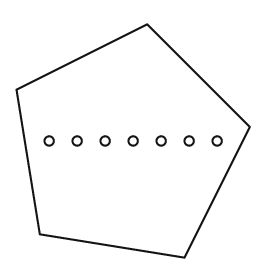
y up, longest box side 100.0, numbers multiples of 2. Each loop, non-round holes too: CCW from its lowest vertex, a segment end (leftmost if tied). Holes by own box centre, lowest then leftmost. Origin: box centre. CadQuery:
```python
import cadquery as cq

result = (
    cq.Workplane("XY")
    .moveTo(22.0, -50.0)
    .lineTo(50.0, 6.0)
    .lineTo(6.0, 50.0)
    .lineTo(-50.0, 22.0)
    .lineTo(-40.0, -40.0)
    .close()
    .moveTo(-36.0, 0.0)
    .circle(2.0)
    .moveTo(-24.0, 0.0)
    .circle(2.0)
    .moveTo(-12.0, 0.0)
    .circle(2.0)
    .moveTo(0.0, 0.0)
    .circle(2.0)
    .moveTo(12.0, 0.0)
    .circle(2.0)
    .moveTo(24.0, 0.0)
    .circle(2.0)
    .moveTo(36.0, 0.0)
    .circle(2.0)
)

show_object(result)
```